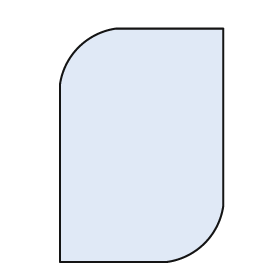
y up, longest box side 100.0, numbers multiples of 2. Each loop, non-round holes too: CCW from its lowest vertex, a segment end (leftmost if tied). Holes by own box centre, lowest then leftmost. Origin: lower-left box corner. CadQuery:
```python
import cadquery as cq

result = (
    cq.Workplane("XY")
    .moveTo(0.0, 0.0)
    .lineTo(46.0, 0.0)
    .threePointArc((62.0, 8.0), (70.0, 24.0))
    .lineTo(70.0, 100.0)
    .lineTo(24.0, 100.0)
    .threePointArc((8.0, 92.0), (0.0, 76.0))
    .close()
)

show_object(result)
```